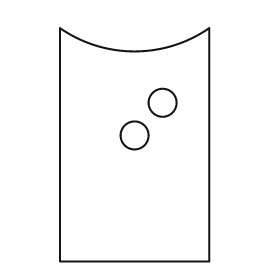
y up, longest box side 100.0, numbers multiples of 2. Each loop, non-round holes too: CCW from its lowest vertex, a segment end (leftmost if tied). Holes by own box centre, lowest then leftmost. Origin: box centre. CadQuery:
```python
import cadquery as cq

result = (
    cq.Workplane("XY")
    .moveTo(-32.0, -50.0)
    .lineTo(32.0, -50.0)
    .lineTo(32.0, 50.0)
    .threePointArc((0.0, 40.0), (-32.0, 50.0))
    .close()
    .moveTo(0.0, 4.0)
    .circle(6.0)
    .moveTo(12.0, 18.0)
    .circle(6.0)
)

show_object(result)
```